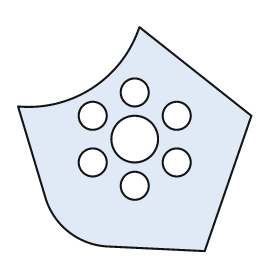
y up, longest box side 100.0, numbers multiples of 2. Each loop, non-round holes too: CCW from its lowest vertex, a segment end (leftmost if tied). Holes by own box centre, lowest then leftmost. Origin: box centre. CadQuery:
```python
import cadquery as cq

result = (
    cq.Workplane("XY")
    .moveTo(30.0, -48.0)
    .lineTo(50.0, 10.0)
    .lineTo(2.0, 48.0)
    .threePointArc((-18.0, 22.0), (-50.0, 14.0))
    .lineTo(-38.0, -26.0)
    .threePointArc((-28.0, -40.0), (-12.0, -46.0))
    .close()
    .moveTo(0.0, -20.0)
    .circle(6.0)
    .moveTo(-18.0, -10.0)
    .circle(6.0)
    .moveTo(18.0, -10.0)
    .circle(6.0)
    .moveTo(0.0, 0.0)
    .circle(10.0)
    .moveTo(-18.0, 10.0)
    .circle(6.0)
    .moveTo(18.0, 10.0)
    .circle(6.0)
    .moveTo(0.0, 20.0)
    .circle(6.0)
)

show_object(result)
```